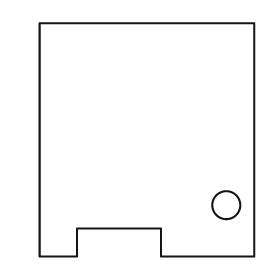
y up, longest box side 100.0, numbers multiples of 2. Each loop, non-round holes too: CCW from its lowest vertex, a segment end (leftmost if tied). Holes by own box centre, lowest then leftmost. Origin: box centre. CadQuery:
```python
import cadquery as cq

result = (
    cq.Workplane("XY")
    .moveTo(-46.0, -50.0)
    .lineTo(-30.0, -50.0)
    .lineTo(-30.0, -38.0)
    .lineTo(6.0, -38.0)
    .lineTo(6.0, -50.0)
    .lineTo(46.0, -50.0)
    .lineTo(46.0, 50.0)
    .lineTo(-46.0, 50.0)
    .close()
    .moveTo(34.0, -28.0)
    .circle(6.0)
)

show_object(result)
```